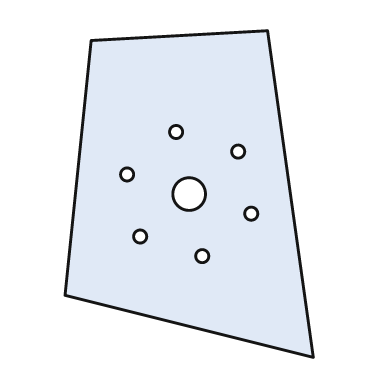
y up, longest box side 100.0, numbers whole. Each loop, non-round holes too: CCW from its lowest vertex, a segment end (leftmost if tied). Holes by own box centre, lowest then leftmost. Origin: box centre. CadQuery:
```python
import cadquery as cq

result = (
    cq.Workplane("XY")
    .moveTo(38.0, -50.0)
    .lineTo(24.0, 50.0)
    .lineTo(-30.0, 47.0)
    .lineTo(-38.0, -31.0)
    .close()
    .moveTo(4.0, -19.0)
    .circle(2.0)
    .moveTo(-15.0, -13.0)
    .circle(2.0)
    .moveTo(19.0, -6.0)
    .circle(2.0)
    .moveTo(0.0, 0.0)
    .circle(5.0)
    .moveTo(-19.0, 6.0)
    .circle(2.0)
    .moveTo(15.0, 13.0)
    .circle(2.0)
    .moveTo(-4.0, 19.0)
    .circle(2.0)
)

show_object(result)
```